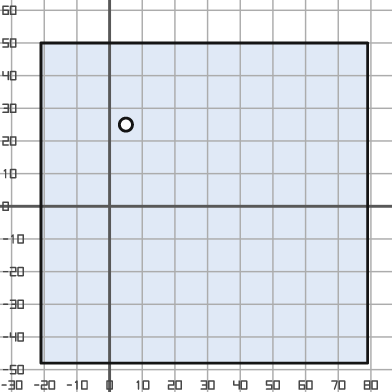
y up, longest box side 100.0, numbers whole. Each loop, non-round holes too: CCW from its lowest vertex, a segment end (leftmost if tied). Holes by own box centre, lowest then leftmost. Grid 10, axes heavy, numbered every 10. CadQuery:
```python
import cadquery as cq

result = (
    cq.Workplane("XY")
    .moveTo(-21.0, -48.0)
    .lineTo(79.0, -48.0)
    .lineTo(79.0, 50.0)
    .lineTo(-21.0, 50.0)
    .close()
    .moveTo(5.0, 25.0)
    .circle(2.0)
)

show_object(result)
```